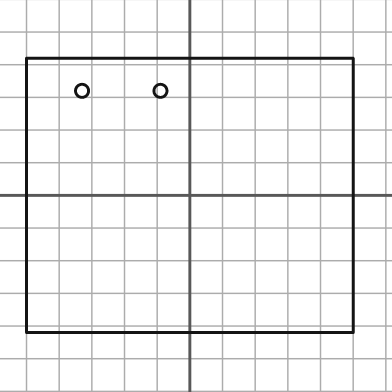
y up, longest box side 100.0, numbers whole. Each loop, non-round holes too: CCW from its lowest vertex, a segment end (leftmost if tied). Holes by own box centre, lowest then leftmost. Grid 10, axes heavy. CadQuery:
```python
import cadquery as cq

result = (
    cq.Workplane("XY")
    .moveTo(-50.0, -42.0)
    .lineTo(50.0, -42.0)
    .lineTo(50.0, 42.0)
    .lineTo(-50.0, 42.0)
    .close()
    .moveTo(-33.0, 32.0)
    .circle(2.0)
    .moveTo(-9.0, 32.0)
    .circle(2.0)
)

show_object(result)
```